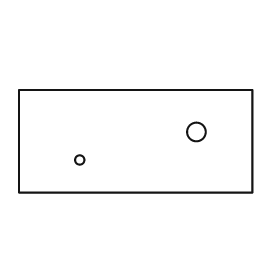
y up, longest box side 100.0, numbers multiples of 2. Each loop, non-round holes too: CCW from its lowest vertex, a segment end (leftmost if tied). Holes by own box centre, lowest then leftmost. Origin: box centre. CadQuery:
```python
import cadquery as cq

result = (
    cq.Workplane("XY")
    .moveTo(-50.0, -22.0)
    .lineTo(50.0, -22.0)
    .lineTo(50.0, 22.0)
    .lineTo(-50.0, 22.0)
    .close()
    .moveTo(-24.0, -8.0)
    .circle(2.0)
    .moveTo(26.0, 4.0)
    .circle(4.0)
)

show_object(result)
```